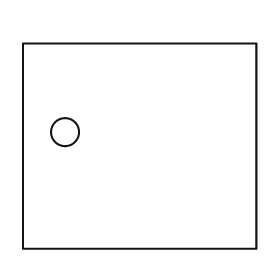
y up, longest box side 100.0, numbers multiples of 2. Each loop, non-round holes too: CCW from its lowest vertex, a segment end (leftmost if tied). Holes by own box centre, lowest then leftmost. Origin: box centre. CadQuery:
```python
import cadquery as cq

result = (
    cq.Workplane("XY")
    .moveTo(-50.0, -44.0)
    .lineTo(50.0, -44.0)
    .lineTo(50.0, 44.0)
    .lineTo(-50.0, 44.0)
    .close()
    .moveTo(-32.0, 6.0)
    .circle(6.0)
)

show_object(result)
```